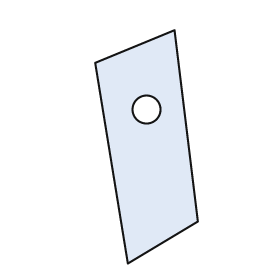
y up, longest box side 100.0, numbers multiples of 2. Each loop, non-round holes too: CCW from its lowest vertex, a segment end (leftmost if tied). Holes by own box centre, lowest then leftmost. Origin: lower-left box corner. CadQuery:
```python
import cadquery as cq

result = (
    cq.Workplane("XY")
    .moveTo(14.0, 0.0)
    .lineTo(44.0, 18.0)
    .lineTo(34.0, 100.0)
    .lineTo(0.0, 86.0)
    .close()
    .moveTo(22.0, 66.0)
    .circle(6.0)
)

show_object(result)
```